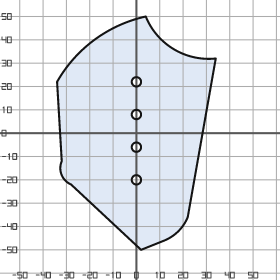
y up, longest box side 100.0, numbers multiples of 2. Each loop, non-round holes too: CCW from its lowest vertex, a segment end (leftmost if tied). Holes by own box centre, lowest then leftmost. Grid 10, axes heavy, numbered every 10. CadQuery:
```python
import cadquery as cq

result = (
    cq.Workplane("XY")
    .moveTo(2.0, -50.0)
    .lineTo(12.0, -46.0)
    .threePointArc((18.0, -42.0), (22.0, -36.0))
    .lineTo(34.0, 32.0)
    .threePointArc((16.0, 36.0), (4.0, 50.0))
    .threePointArc((-18.0, 40.0), (-34.0, 22.0))
    .lineTo(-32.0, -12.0)
    .threePointArc((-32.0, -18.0), (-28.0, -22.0))
    .close()
    .moveTo(0.0, -20.0)
    .circle(2.0)
    .moveTo(0.0, -6.0)
    .circle(2.0)
    .moveTo(0.0, 8.0)
    .circle(2.0)
    .moveTo(0.0, 22.0)
    .circle(2.0)
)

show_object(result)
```